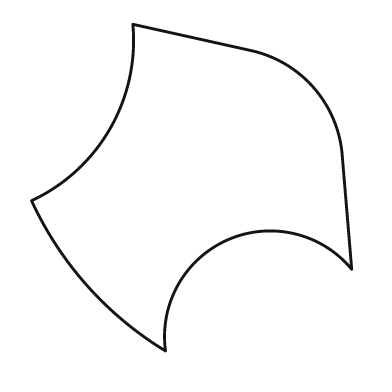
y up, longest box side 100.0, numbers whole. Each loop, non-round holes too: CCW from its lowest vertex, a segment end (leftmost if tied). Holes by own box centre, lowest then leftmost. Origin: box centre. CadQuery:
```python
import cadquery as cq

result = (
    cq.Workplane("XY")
    .moveTo(-8.0, -50.0)
    .threePointArc((11.0, -16.0), (49.0, -25.0))
    .lineTo(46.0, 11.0)
    .threePointArc((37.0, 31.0), (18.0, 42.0))
    .lineTo(-18.0, 50.0)
    .threePointArc((-25.0, 18.0), (-49.0, -4.0))
    .threePointArc((-32.0, -30.0), (-8.0, -50.0))
    .close()
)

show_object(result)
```